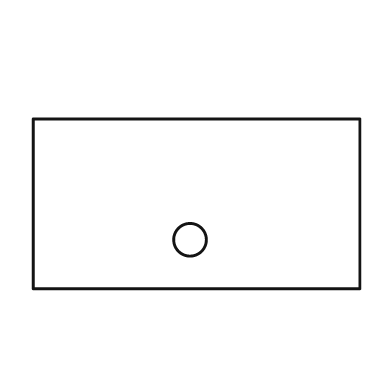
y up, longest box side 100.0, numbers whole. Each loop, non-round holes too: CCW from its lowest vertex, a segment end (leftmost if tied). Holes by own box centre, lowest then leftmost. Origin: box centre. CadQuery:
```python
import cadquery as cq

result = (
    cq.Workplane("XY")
    .moveTo(-50.0, -26.0)
    .lineTo(50.0, -26.0)
    .lineTo(50.0, 26.0)
    .lineTo(-50.0, 26.0)
    .close()
    .moveTo(-2.0, -11.0)
    .circle(5.0)
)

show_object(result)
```